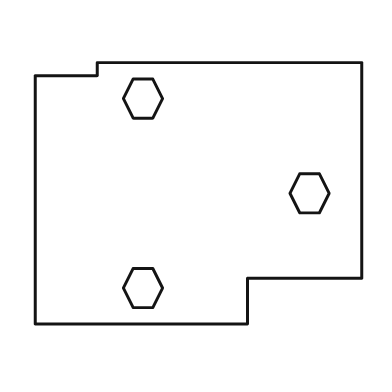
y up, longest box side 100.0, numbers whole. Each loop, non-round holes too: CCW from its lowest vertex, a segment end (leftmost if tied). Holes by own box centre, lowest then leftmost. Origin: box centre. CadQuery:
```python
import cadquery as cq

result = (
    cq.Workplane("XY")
    .moveTo(-50.0, -40.0)
    .lineTo(15.0, -40.0)
    .lineTo(15.0, -26.0)
    .lineTo(50.0, -26.0)
    .lineTo(50.0, 40.0)
    .lineTo(-31.0, 40.0)
    .lineTo(-31.0, 36.0)
    .lineTo(-50.0, 36.0)
    .close()
    .moveTo(-20.0, -35.0)
    .lineTo(-14.0, -35.0)
    .lineTo(-11.0, -29.0)
    .lineTo(-14.0, -23.0)
    .lineTo(-20.0, -23.0)
    .lineTo(-23.0, -29.0)
    .close()
    .moveTo(31.0, -6.0)
    .lineTo(37.0, -6.0)
    .lineTo(40.0, 0.0)
    .lineTo(37.0, 6.0)
    .lineTo(31.0, 6.0)
    .lineTo(28.0, 0.0)
    .close()
    .moveTo(-20.0, 23.0)
    .lineTo(-14.0, 23.0)
    .lineTo(-11.0, 29.0)
    .lineTo(-14.0, 35.0)
    .lineTo(-20.0, 35.0)
    .lineTo(-23.0, 29.0)
    .close()
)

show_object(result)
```